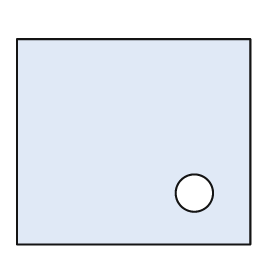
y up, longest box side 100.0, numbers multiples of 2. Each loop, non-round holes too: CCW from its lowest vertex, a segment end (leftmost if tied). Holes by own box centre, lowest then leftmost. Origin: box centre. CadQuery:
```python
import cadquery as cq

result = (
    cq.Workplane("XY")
    .moveTo(-50.0, -44.0)
    .lineTo(50.0, -44.0)
    .lineTo(50.0, 44.0)
    .lineTo(-50.0, 44.0)
    .close()
    .moveTo(26.0, -22.0)
    .circle(8.0)
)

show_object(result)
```